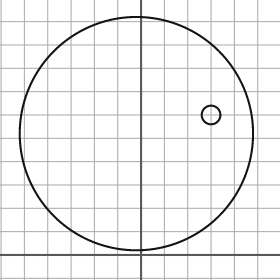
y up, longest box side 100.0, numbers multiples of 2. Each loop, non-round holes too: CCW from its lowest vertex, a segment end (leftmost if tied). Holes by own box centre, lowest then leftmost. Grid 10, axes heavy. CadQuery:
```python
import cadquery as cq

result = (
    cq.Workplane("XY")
    .moveTo(-2.0, 52.0)
    .circle(50.0)
    .moveTo(30.0, 60.0)
    .circle(4.0)
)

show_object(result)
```